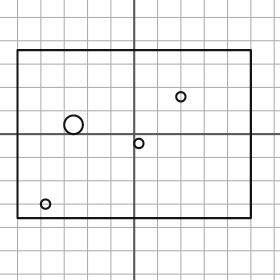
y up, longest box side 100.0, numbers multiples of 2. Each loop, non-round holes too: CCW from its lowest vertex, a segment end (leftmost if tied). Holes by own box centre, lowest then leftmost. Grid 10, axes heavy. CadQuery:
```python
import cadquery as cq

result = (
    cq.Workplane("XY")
    .moveTo(-50.0, -36.0)
    .lineTo(50.0, -36.0)
    .lineTo(50.0, 36.0)
    .lineTo(-50.0, 36.0)
    .close()
    .moveTo(-38.0, -30.0)
    .circle(2.0)
    .moveTo(2.0, -4.0)
    .circle(2.0)
    .moveTo(-26.0, 4.0)
    .circle(4.0)
    .moveTo(20.0, 16.0)
    .circle(2.0)
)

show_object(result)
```